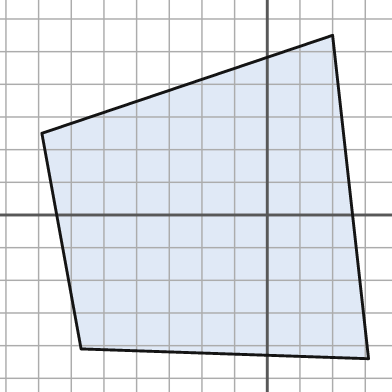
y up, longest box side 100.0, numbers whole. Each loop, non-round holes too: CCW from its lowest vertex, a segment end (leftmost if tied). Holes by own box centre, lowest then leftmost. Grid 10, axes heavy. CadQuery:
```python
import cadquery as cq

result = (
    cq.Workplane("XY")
    .moveTo(31.0, -44.0)
    .lineTo(20.0, 55.0)
    .lineTo(-69.0, 25.0)
    .lineTo(-57.0, -41.0)
    .close()
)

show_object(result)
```